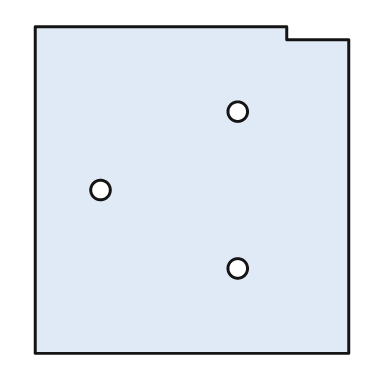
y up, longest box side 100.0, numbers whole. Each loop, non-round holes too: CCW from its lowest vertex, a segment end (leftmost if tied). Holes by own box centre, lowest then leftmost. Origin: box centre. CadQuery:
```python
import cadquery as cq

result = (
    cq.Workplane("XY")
    .moveTo(-48.0, -50.0)
    .lineTo(48.0, -50.0)
    .lineTo(48.0, 46.0)
    .lineTo(29.0, 46.0)
    .lineTo(29.0, 50.0)
    .lineTo(-48.0, 50.0)
    .close()
    .moveTo(14.0, -24.0)
    .circle(3.0)
    .moveTo(-28.0, 0.0)
    .circle(3.0)
    .moveTo(14.0, 24.0)
    .circle(3.0)
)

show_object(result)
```